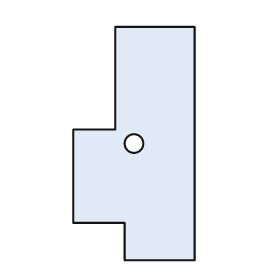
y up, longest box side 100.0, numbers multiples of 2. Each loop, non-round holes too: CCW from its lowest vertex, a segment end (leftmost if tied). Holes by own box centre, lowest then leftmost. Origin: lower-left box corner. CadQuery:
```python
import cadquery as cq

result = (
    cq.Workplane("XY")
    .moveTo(22.0, 0.0)
    .lineTo(52.0, 0.0)
    .lineTo(52.0, 100.0)
    .lineTo(18.0, 100.0)
    .lineTo(18.0, 56.0)
    .lineTo(0.0, 56.0)
    .lineTo(0.0, 16.0)
    .lineTo(22.0, 16.0)
    .close()
    .moveTo(26.0, 50.0)
    .circle(4.0)
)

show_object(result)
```